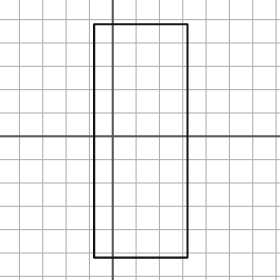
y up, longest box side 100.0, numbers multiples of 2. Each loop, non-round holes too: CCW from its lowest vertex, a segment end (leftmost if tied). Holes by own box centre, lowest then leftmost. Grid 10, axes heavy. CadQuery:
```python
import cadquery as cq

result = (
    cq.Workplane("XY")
    .moveTo(-8.0, -52.0)
    .lineTo(32.0, -52.0)
    .lineTo(32.0, 48.0)
    .lineTo(-8.0, 48.0)
    .close()
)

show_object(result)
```